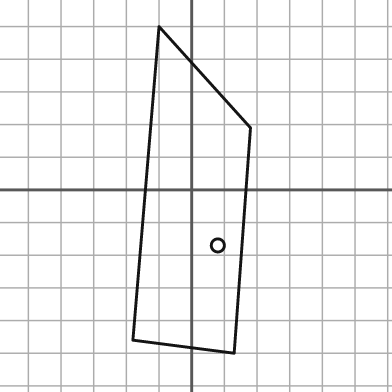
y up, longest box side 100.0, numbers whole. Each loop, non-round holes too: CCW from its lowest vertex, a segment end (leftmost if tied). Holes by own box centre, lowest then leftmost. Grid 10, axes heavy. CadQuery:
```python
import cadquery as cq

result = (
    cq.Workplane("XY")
    .moveTo(13.0, -50.0)
    .lineTo(18.0, 19.0)
    .lineTo(-10.0, 50.0)
    .lineTo(-18.0, -46.0)
    .close()
    .moveTo(8.0, -17.0)
    .circle(2.0)
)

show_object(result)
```